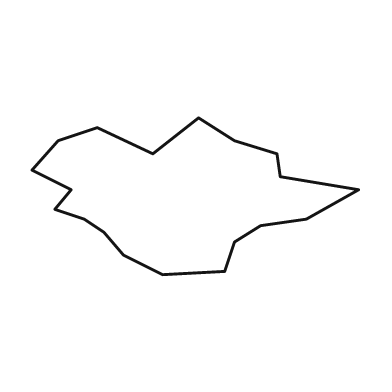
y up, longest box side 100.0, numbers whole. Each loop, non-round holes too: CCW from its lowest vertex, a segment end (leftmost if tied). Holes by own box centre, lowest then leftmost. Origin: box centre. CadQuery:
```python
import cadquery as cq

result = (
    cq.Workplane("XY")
    .moveTo(-10.0, -24.0)
    .lineTo(9.0, -23.0)
    .lineTo(12.0, -14.0)
    .lineTo(20.0, -9.0)
    .lineTo(34.0, -7.0)
    .lineTo(50.0, 2.0)
    .lineTo(26.0, 6.0)
    .lineTo(25.0, 13.0)
    .lineTo(12.0, 17.0)
    .lineTo(1.0, 24.0)
    .lineTo(-13.0, 13.0)
    .lineTo(-30.0, 21.0)
    .lineTo(-42.0, 17.0)
    .lineTo(-50.0, 8.0)
    .lineTo(-38.0, 2.0)
    .lineTo(-43.0, -4.0)
    .lineTo(-34.0, -7.0)
    .lineTo(-28.0, -11.0)
    .lineTo(-22.0, -18.0)
    .close()
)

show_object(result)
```